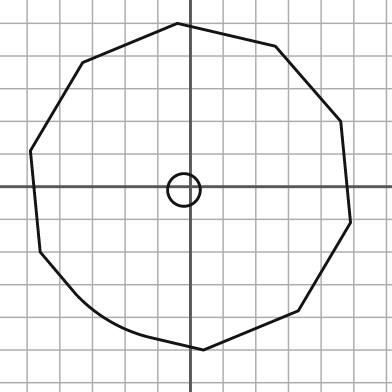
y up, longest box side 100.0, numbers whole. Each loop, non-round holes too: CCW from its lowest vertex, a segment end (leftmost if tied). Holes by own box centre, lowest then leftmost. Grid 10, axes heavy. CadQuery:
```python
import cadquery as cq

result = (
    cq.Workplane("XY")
    .moveTo(4.0, -50.0)
    .lineTo(33.0, -38.0)
    .lineTo(49.0, -11.0)
    .lineTo(46.0, 20.0)
    .lineTo(26.0, 43.0)
    .lineTo(-4.0, 50.0)
    .lineTo(-33.0, 38.0)
    .lineTo(-49.0, 11.0)
    .lineTo(-46.0, -20.0)
    .lineTo(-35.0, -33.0)
    .threePointArc((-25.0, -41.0), (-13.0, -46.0))
    .close()
    .moveTo(-2.0, -1.0)
    .circle(5.0)
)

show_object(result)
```